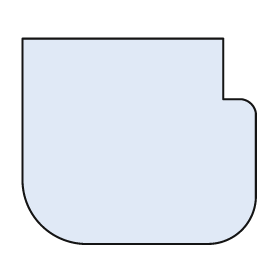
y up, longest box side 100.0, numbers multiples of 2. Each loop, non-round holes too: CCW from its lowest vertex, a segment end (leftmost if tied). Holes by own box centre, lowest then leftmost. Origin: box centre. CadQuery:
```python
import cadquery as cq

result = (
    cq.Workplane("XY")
    .moveTo(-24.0, -44.0)
    .lineTo(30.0, -44.0)
    .threePointArc((44.0, -38.0), (50.0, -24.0))
    .lineTo(50.0, 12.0)
    .threePointArc((48.0, 16.0), (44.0, 18.0))
    .lineTo(36.0, 18.0)
    .lineTo(36.0, 44.0)
    .lineTo(-50.0, 44.0)
    .lineTo(-50.0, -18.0)
    .threePointArc((-42.0, -36.0), (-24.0, -44.0))
    .close()
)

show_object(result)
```